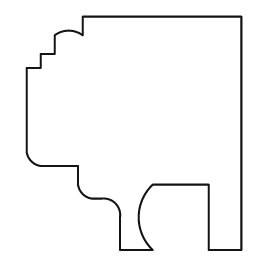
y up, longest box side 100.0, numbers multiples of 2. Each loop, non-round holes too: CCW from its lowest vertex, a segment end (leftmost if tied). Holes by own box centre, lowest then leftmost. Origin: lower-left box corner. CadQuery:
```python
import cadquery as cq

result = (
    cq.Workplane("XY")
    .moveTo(40.0, 0.0)
    .lineTo(54.0, 0.0)
    .threePointArc((48.0, 14.0), (54.0, 28.0))
    .lineTo(78.0, 28.0)
    .lineTo(78.0, 0.0)
    .lineTo(92.0, 0.0)
    .lineTo(92.0, 100.0)
    .lineTo(24.0, 100.0)
    .lineTo(24.0, 92.0)
    .threePointArc((18.0, 94.0), (12.0, 92.0))
    .lineTo(12.0, 84.0)
    .lineTo(6.0, 84.0)
    .lineTo(6.0, 78.0)
    .lineTo(0.0, 78.0)
    .lineTo(0.0, 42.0)
    .threePointArc((2.0, 38.0), (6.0, 36.0))
    .lineTo(22.0, 36.0)
    .lineTo(22.0, 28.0)
    .threePointArc((24.0, 24.0), (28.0, 22.0))
    .lineTo(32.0, 22.0)
    .threePointArc((38.0, 20.0), (40.0, 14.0))
    .close()
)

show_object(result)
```